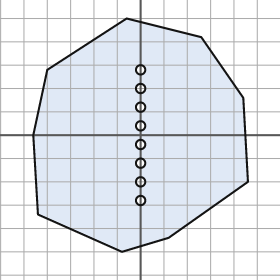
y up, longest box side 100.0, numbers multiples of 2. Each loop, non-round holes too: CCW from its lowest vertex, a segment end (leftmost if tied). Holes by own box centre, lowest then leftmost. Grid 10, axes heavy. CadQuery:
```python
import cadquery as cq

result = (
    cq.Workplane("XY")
    .moveTo(-8.0, -50.0)
    .lineTo(12.0, -44.0)
    .lineTo(46.0, -20.0)
    .lineTo(44.0, 16.0)
    .lineTo(26.0, 42.0)
    .lineTo(-6.0, 50.0)
    .lineTo(-40.0, 28.0)
    .lineTo(-46.0, 0.0)
    .lineTo(-44.0, -34.0)
    .close()
    .moveTo(0.0, -28.0)
    .circle(2.0)
    .moveTo(0.0, -20.0)
    .circle(2.0)
    .moveTo(0.0, -12.0)
    .circle(2.0)
    .moveTo(0.0, -4.0)
    .circle(2.0)
    .moveTo(0.0, 4.0)
    .circle(2.0)
    .moveTo(0.0, 12.0)
    .circle(2.0)
    .moveTo(0.0, 20.0)
    .circle(2.0)
    .moveTo(0.0, 28.0)
    .circle(2.0)
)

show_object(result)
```